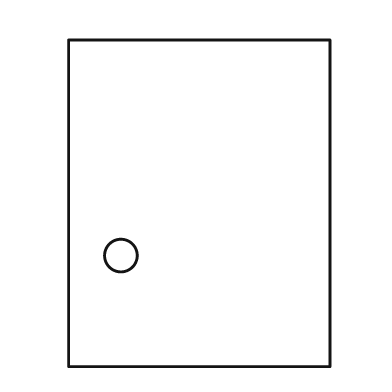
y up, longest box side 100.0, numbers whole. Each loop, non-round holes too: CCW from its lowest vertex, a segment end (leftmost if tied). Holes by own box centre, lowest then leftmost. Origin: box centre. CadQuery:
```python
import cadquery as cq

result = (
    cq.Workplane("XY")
    .moveTo(-40.0, -50.0)
    .lineTo(40.0, -50.0)
    .lineTo(40.0, 50.0)
    .lineTo(-40.0, 50.0)
    .close()
    .moveTo(-24.0, -16.0)
    .circle(5.0)
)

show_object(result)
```